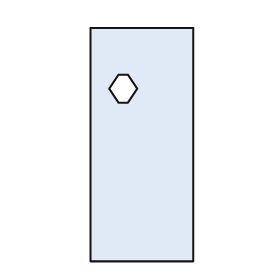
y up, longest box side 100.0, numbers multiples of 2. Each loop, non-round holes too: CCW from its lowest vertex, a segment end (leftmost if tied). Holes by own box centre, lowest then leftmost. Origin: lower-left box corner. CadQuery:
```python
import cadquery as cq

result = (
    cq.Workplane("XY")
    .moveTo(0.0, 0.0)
    .lineTo(44.0, 0.0)
    .lineTo(44.0, 100.0)
    .lineTo(0.0, 100.0)
    .close()
    .moveTo(12.0, 68.0)
    .lineTo(16.0, 68.0)
    .lineTo(20.0, 74.0)
    .lineTo(16.0, 80.0)
    .lineTo(12.0, 80.0)
    .lineTo(8.0, 74.0)
    .close()
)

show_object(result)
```